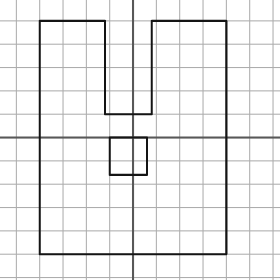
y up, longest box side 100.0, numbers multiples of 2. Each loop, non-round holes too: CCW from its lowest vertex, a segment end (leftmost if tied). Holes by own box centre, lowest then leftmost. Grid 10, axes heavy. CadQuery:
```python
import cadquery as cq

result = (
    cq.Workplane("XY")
    .moveTo(-40.0, -50.0)
    .lineTo(40.0, -50.0)
    .lineTo(40.0, 50.0)
    .lineTo(8.0, 50.0)
    .lineTo(8.0, 10.0)
    .lineTo(-12.0, 10.0)
    .lineTo(-12.0, 50.0)
    .lineTo(-40.0, 50.0)
    .close()
    .moveTo(-10.0, -16.0)
    .lineTo(6.0, -16.0)
    .lineTo(6.0, 0.0)
    .lineTo(-10.0, 0.0)
    .close()
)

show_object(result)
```